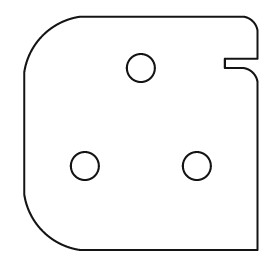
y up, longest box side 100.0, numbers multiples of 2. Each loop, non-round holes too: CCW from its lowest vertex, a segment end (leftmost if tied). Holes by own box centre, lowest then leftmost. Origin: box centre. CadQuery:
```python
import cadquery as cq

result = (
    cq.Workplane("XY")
    .moveTo(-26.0, -50.0)
    .lineTo(50.0, -50.0)
    .lineTo(50.0, 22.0)
    .threePointArc((48.0, 26.0), (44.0, 28.0))
    .lineTo(36.0, 28.0)
    .lineTo(36.0, 32.0)
    .lineTo(50.0, 32.0)
    .lineTo(50.0, 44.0)
    .threePointArc((48.0, 48.0), (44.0, 50.0))
    .lineTo(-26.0, 50.0)
    .threePointArc((-42.0, 42.0), (-50.0, 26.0))
    .lineTo(-50.0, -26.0)
    .threePointArc((-42.0, -42.0), (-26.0, -50.0))
    .close()
    .moveTo(-24.0, -14.0)
    .circle(6.0)
    .moveTo(24.0, -14.0)
    .circle(6.0)
    .moveTo(0.0, 28.0)
    .circle(6.0)
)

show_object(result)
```